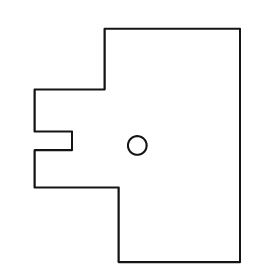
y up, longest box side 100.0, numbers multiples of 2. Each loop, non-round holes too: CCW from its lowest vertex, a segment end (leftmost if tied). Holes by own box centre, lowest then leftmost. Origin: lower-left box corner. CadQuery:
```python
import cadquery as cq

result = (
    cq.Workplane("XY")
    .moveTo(36.0, 0.0)
    .lineTo(88.0, 0.0)
    .lineTo(88.0, 100.0)
    .lineTo(30.0, 100.0)
    .lineTo(30.0, 74.0)
    .lineTo(0.0, 74.0)
    .lineTo(0.0, 56.0)
    .lineTo(16.0, 56.0)
    .lineTo(16.0, 48.0)
    .lineTo(0.0, 48.0)
    .lineTo(0.0, 32.0)
    .lineTo(36.0, 32.0)
    .close()
    .moveTo(44.0, 50.0)
    .circle(4.0)
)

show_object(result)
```